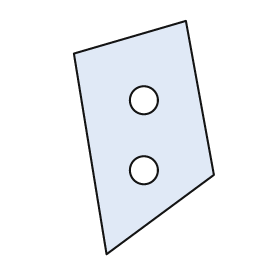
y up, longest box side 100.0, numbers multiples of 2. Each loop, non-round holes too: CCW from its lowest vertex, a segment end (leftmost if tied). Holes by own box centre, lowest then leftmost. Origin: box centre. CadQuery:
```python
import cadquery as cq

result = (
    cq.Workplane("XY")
    .moveTo(-16.0, -50.0)
    .lineTo(30.0, -16.0)
    .lineTo(18.0, 50.0)
    .lineTo(-30.0, 36.0)
    .close()
    .moveTo(0.0, -14.0)
    .circle(6.0)
    .moveTo(0.0, 16.0)
    .circle(6.0)
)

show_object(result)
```